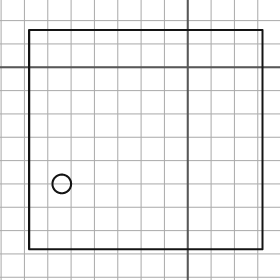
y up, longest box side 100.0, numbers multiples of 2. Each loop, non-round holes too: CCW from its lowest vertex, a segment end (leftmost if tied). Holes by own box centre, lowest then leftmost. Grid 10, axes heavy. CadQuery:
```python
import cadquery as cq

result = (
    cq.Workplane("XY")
    .moveTo(-68.0, -78.0)
    .lineTo(32.0, -78.0)
    .lineTo(32.0, 16.0)
    .lineTo(-68.0, 16.0)
    .close()
    .moveTo(-54.0, -50.0)
    .circle(4.0)
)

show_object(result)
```